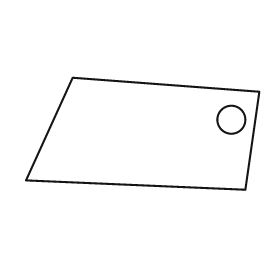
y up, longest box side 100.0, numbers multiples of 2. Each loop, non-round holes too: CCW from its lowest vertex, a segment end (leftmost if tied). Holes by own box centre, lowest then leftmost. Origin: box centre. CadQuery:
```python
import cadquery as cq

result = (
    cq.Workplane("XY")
    .moveTo(44.0, -24.0)
    .lineTo(50.0, 18.0)
    .lineTo(-30.0, 24.0)
    .lineTo(-50.0, -20.0)
    .close()
    .moveTo(38.0, 6.0)
    .circle(6.0)
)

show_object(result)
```